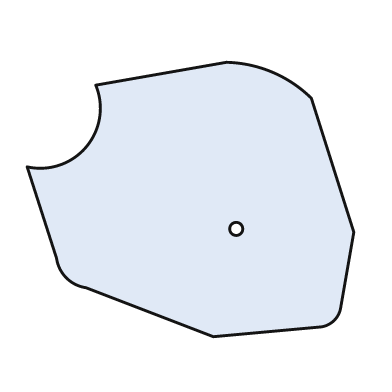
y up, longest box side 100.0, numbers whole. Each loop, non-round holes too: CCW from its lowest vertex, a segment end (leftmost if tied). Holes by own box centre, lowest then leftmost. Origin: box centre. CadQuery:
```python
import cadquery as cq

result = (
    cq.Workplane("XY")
    .moveTo(7.0, -42.0)
    .lineTo(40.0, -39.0)
    .threePointArc((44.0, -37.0), (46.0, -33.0))
    .lineTo(50.0, -10.0)
    .lineTo(37.0, 31.0)
    .threePointArc((25.0, 39.0), (11.0, 42.0))
    .lineTo(-29.0, 35.0)
    .threePointArc((-32.0, 16.0), (-50.0, 10.0))
    .lineTo(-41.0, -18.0)
    .threePointArc((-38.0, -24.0), (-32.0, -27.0))
    .close()
    .moveTo(14.0, -9.0)
    .circle(2.0)
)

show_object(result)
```